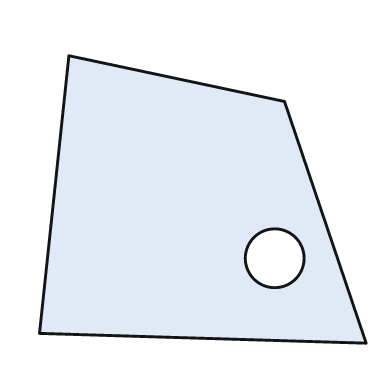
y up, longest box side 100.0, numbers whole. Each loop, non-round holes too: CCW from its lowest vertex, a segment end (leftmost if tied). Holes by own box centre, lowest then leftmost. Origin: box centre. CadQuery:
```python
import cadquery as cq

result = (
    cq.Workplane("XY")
    .moveTo(50.0, -44.0)
    .lineTo(25.0, 30.0)
    .lineTo(-41.0, 44.0)
    .lineTo(-50.0, -41.0)
    .close()
    .moveTo(22.0, -18.0)
    .circle(9.0)
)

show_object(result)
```